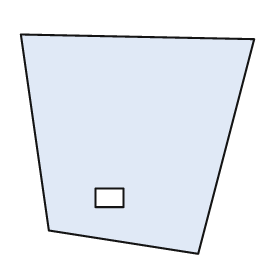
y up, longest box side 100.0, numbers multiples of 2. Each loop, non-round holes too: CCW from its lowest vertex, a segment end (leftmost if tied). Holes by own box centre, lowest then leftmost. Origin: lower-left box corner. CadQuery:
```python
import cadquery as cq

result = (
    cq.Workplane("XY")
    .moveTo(76.0, 0.0)
    .lineTo(100.0, 92.0)
    .lineTo(0.0, 94.0)
    .lineTo(12.0, 10.0)
    .close()
    .moveTo(32.0, 20.0)
    .lineTo(44.0, 20.0)
    .lineTo(44.0, 28.0)
    .lineTo(32.0, 28.0)
    .close()
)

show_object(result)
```